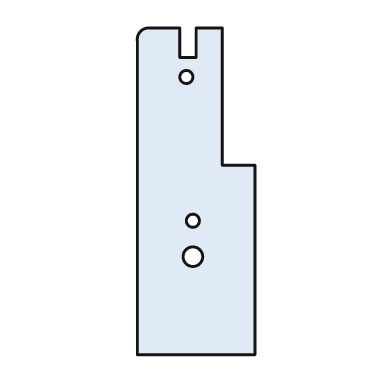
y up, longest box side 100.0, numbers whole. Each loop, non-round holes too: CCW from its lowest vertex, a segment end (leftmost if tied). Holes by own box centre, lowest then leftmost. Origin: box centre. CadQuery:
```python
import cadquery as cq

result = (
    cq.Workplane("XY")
    .moveTo(-18.0, -50.0)
    .lineTo(18.0, -50.0)
    .lineTo(18.0, 8.0)
    .lineTo(8.0, 8.0)
    .lineTo(8.0, 50.0)
    .lineTo(0.0, 50.0)
    .lineTo(0.0, 41.0)
    .lineTo(-5.0, 41.0)
    .lineTo(-5.0, 50.0)
    .lineTo(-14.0, 50.0)
    .threePointArc((-17.0, 49.0), (-18.0, 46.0))
    .close()
    .moveTo(-1.0, -20.0)
    .circle(3.0)
    .moveTo(-1.0, -9.0)
    .circle(2.0)
    .moveTo(-3.0, 35.0)
    .circle(2.0)
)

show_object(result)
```